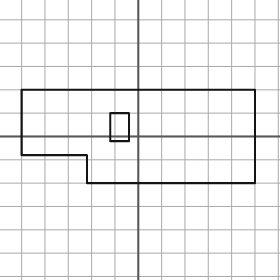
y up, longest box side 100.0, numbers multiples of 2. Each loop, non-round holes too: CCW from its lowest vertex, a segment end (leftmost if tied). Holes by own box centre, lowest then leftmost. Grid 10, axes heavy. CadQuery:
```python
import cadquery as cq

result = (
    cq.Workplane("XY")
    .moveTo(-22.0, -20.0)
    .lineTo(50.0, -20.0)
    .lineTo(50.0, 20.0)
    .lineTo(-50.0, 20.0)
    .lineTo(-50.0, -8.0)
    .lineTo(-22.0, -8.0)
    .close()
    .moveTo(-12.0, -2.0)
    .lineTo(-4.0, -2.0)
    .lineTo(-4.0, 10.0)
    .lineTo(-12.0, 10.0)
    .close()
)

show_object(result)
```